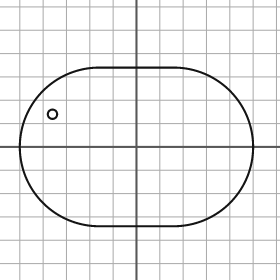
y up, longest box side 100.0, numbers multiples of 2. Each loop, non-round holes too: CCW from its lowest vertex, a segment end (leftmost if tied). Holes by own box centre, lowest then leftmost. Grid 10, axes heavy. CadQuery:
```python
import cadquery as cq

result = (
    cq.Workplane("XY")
    .moveTo(-16.0, -34.0)
    .lineTo(16.0, -34.0)
    .threePointArc((50.0, 0.0), (16.0, 34.0))
    .lineTo(-16.0, 34.0)
    .threePointArc((-50.0, 0.0), (-16.0, -34.0))
    .close()
    .moveTo(-36.0, 14.0)
    .circle(2.0)
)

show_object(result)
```